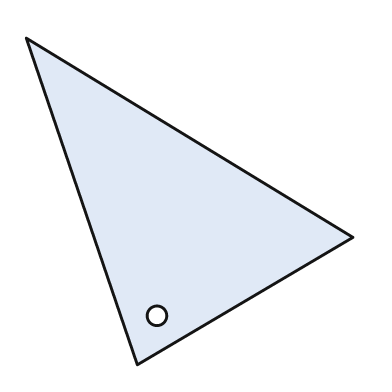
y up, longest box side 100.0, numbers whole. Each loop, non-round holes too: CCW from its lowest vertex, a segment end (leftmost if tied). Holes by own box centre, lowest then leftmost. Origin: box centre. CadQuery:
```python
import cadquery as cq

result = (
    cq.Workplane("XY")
    .moveTo(-16.0, -50.0)
    .lineTo(50.0, -11.0)
    .lineTo(-50.0, 50.0)
    .close()
    .moveTo(-10.0, -35.0)
    .circle(3.0)
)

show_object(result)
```